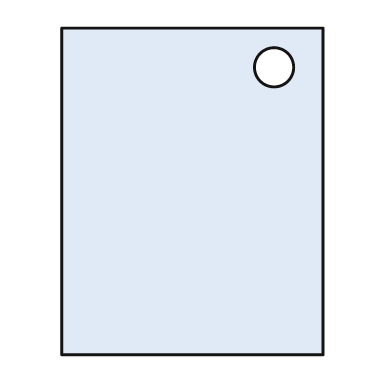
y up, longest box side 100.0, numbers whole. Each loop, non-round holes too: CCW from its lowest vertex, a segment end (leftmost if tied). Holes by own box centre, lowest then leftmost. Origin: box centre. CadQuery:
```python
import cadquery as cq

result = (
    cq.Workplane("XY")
    .moveTo(-40.0, -50.0)
    .lineTo(40.0, -50.0)
    .lineTo(40.0, 50.0)
    .lineTo(-40.0, 50.0)
    .close()
    .moveTo(25.0, 38.0)
    .circle(6.0)
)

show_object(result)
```